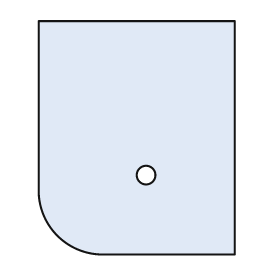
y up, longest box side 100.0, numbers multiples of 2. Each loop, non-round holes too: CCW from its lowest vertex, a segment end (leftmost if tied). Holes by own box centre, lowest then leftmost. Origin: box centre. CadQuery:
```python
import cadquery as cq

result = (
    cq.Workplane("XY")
    .moveTo(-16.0, -50.0)
    .lineTo(42.0, -50.0)
    .lineTo(42.0, 50.0)
    .lineTo(-42.0, 50.0)
    .lineTo(-42.0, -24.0)
    .threePointArc((-34.0, -42.0), (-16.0, -50.0))
    .close()
    .moveTo(4.0, -16.0)
    .circle(4.0)
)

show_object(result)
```